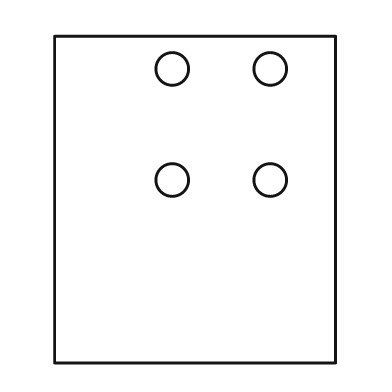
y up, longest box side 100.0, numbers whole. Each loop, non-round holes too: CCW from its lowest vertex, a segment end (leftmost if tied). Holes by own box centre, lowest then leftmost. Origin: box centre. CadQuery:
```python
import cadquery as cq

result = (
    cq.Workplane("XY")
    .moveTo(-43.0, -50.0)
    .lineTo(43.0, -50.0)
    .lineTo(43.0, 50.0)
    .lineTo(-43.0, 50.0)
    .close()
    .moveTo(-7.0, 6.0)
    .circle(5.0)
    .moveTo(23.0, 6.0)
    .circle(5.0)
    .moveTo(-7.0, 40.0)
    .circle(5.0)
    .moveTo(23.0, 40.0)
    .circle(5.0)
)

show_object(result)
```